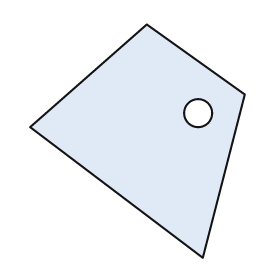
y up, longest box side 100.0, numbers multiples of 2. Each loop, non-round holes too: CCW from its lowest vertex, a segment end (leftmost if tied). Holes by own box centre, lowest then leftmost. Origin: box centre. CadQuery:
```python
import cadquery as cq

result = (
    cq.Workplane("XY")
    .moveTo(28.0, -50.0)
    .lineTo(46.0, 20.0)
    .lineTo(4.0, 50.0)
    .lineTo(-46.0, 6.0)
    .close()
    .moveTo(26.0, 12.0)
    .circle(6.0)
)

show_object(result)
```